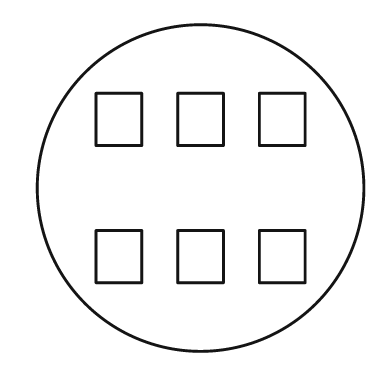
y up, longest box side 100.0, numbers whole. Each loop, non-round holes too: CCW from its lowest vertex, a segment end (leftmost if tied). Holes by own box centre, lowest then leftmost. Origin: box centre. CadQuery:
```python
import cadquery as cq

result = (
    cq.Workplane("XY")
    .moveTo(0.0, 0.0)
    .circle(50.0)
    .moveTo(-32.0, -29.0)
    .lineTo(-18.0, -29.0)
    .lineTo(-18.0, -13.0)
    .lineTo(-32.0, -13.0)
    .close()
    .moveTo(-7.0, -29.0)
    .lineTo(7.0, -29.0)
    .lineTo(7.0, -13.0)
    .lineTo(-7.0, -13.0)
    .close()
    .moveTo(18.0, -29.0)
    .lineTo(32.0, -29.0)
    .lineTo(32.0, -13.0)
    .lineTo(18.0, -13.0)
    .close()
    .moveTo(-32.0, 13.0)
    .lineTo(-18.0, 13.0)
    .lineTo(-18.0, 29.0)
    .lineTo(-32.0, 29.0)
    .close()
    .moveTo(-7.0, 13.0)
    .lineTo(7.0, 13.0)
    .lineTo(7.0, 29.0)
    .lineTo(-7.0, 29.0)
    .close()
    .moveTo(18.0, 13.0)
    .lineTo(32.0, 13.0)
    .lineTo(32.0, 29.0)
    .lineTo(18.0, 29.0)
    .close()
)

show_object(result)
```